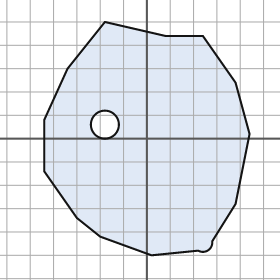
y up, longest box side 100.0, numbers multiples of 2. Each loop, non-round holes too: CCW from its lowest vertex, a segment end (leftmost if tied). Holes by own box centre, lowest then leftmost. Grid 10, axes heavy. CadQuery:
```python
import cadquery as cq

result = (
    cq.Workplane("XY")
    .moveTo(2.0, -50.0)
    .lineTo(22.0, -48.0)
    .threePointArc((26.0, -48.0), (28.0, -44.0))
    .lineTo(38.0, -28.0)
    .lineTo(44.0, 2.0)
    .lineTo(38.0, 24.0)
    .lineTo(24.0, 44.0)
    .lineTo(8.0, 44.0)
    .lineTo(-18.0, 50.0)
    .lineTo(-34.0, 30.0)
    .lineTo(-44.0, 8.0)
    .lineTo(-44.0, -14.0)
    .lineTo(-30.0, -34.0)
    .lineTo(-20.0, -42.0)
    .close()
    .moveTo(-18.0, 6.0)
    .circle(6.0)
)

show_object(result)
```